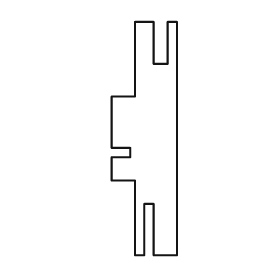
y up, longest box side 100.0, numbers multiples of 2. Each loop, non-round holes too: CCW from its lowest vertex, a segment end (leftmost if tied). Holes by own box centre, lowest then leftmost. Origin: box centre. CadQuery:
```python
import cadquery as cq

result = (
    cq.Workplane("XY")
    .moveTo(-4.0, -50.0)
    .lineTo(0.0, -50.0)
    .lineTo(0.0, -28.0)
    .lineTo(4.0, -28.0)
    .lineTo(4.0, -50.0)
    .lineTo(14.0, -50.0)
    .lineTo(14.0, 50.0)
    .lineTo(10.0, 50.0)
    .lineTo(10.0, 32.0)
    .lineTo(4.0, 32.0)
    .lineTo(4.0, 50.0)
    .lineTo(-4.0, 50.0)
    .lineTo(-4.0, 18.0)
    .lineTo(-14.0, 18.0)
    .lineTo(-14.0, -4.0)
    .lineTo(-6.0, -4.0)
    .lineTo(-6.0, -8.0)
    .lineTo(-14.0, -8.0)
    .lineTo(-14.0, -18.0)
    .lineTo(-4.0, -18.0)
    .close()
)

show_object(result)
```